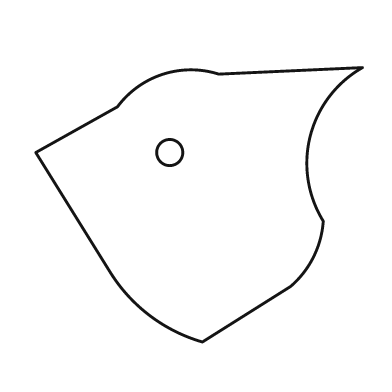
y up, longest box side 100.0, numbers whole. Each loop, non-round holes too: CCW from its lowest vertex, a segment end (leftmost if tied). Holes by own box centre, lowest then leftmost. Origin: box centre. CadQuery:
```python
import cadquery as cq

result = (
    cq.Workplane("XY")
    .moveTo(1.0, -42.0)
    .lineTo(28.0, -25.0)
    .threePointArc((35.0, -16.0), (38.0, -5.0))
    .threePointArc((34.0, 21.0), (50.0, 42.0))
    .lineTo(6.0, 40.0)
    .threePointArc((-11.0, 40.0), (-25.0, 30.0))
    .lineTo(-50.0, 16.0)
    .lineTo(-27.0, -21.0)
    .threePointArc((-15.0, -34.0), (1.0, -42.0))
    .close()
    .moveTo(-9.0, 16.0)
    .circle(4.0)
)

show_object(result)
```